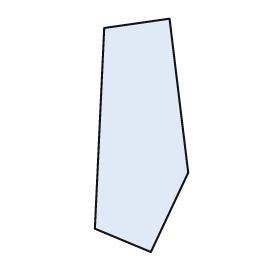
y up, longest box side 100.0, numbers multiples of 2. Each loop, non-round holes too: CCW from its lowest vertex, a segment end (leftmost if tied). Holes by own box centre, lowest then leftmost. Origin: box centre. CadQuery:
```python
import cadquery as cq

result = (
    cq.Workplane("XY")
    .moveTo(4.0, -50.0)
    .lineTo(20.0, -16.0)
    .lineTo(12.0, 50.0)
    .lineTo(-16.0, 46.0)
    .lineTo(-20.0, -40.0)
    .close()
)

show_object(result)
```